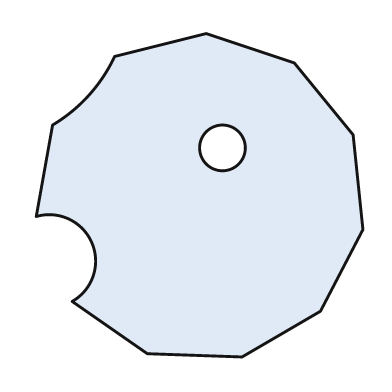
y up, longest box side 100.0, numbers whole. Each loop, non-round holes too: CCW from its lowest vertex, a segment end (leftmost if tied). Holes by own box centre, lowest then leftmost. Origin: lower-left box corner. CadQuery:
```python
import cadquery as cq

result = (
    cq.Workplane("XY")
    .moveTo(63.0, 0.0)
    .lineTo(87.0, 14.0)
    .lineTo(100.0, 39.0)
    .lineTo(97.0, 68.0)
    .lineTo(79.0, 90.0)
    .lineTo(52.0, 99.0)
    .lineTo(24.0, 92.0)
    .threePointArc((16.0, 80.0), (5.0, 71.0))
    .lineTo(0.0, 43.0)
    .threePointArc((17.0, 35.0), (11.0, 17.0))
    .lineTo(34.0, 1.0)
    .close()
    .moveTo(57.0, 64.0)
    .circle(7.0)
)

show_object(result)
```